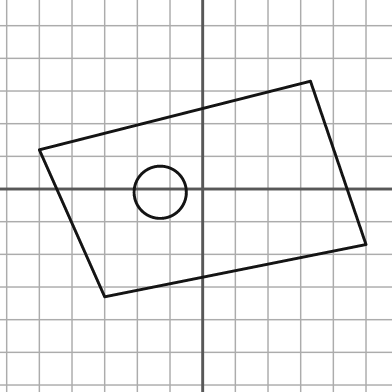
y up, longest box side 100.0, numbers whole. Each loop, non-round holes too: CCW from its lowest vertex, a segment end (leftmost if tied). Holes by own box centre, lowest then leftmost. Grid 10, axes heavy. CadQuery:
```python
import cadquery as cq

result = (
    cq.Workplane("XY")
    .moveTo(-30.0, -33.0)
    .lineTo(50.0, -17.0)
    .lineTo(33.0, 33.0)
    .lineTo(-50.0, 12.0)
    .close()
    .moveTo(-13.0, -1.0)
    .circle(8.0)
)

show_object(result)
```